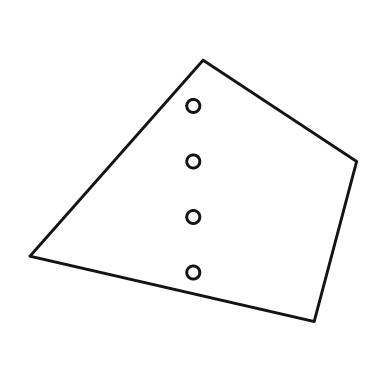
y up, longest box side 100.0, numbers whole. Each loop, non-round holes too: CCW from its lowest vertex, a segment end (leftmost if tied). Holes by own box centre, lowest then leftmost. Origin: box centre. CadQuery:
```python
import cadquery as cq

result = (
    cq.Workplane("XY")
    .moveTo(37.0, -40.0)
    .lineTo(50.0, 9.0)
    .lineTo(3.0, 40.0)
    .lineTo(-50.0, -20.0)
    .close()
    .moveTo(0.0, -25.0)
    .circle(2.0)
    .moveTo(0.0, -8.0)
    .circle(2.0)
    .moveTo(0.0, 9.0)
    .circle(2.0)
    .moveTo(0.0, 26.0)
    .circle(2.0)
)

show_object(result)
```